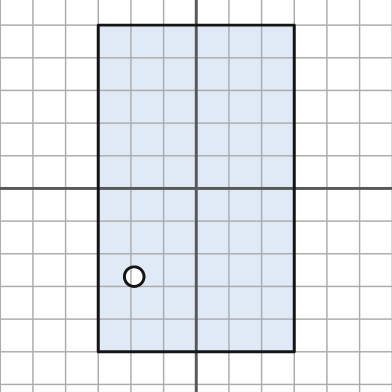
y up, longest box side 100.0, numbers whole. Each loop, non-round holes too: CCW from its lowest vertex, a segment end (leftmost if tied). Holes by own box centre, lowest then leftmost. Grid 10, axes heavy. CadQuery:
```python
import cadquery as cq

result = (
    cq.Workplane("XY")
    .moveTo(-30.0, -50.0)
    .lineTo(30.0, -50.0)
    .lineTo(30.0, 50.0)
    .lineTo(-30.0, 50.0)
    .close()
    .moveTo(-19.0, -27.0)
    .circle(3.0)
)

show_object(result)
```